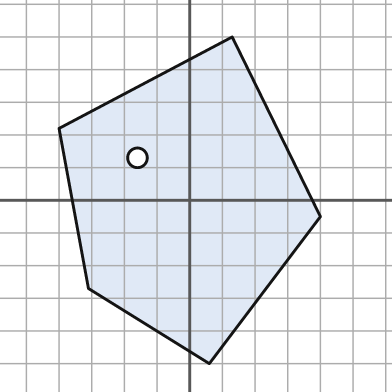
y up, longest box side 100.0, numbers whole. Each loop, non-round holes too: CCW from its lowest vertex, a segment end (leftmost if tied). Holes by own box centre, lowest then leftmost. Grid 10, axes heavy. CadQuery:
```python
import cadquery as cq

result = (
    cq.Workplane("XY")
    .moveTo(6.0, -50.0)
    .lineTo(40.0, -5.0)
    .lineTo(13.0, 50.0)
    .lineTo(-40.0, 22.0)
    .lineTo(-31.0, -27.0)
    .close()
    .moveTo(-16.0, 13.0)
    .circle(3.0)
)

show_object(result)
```